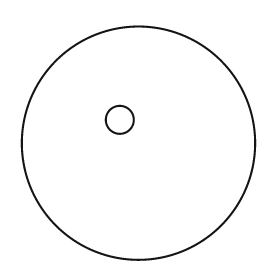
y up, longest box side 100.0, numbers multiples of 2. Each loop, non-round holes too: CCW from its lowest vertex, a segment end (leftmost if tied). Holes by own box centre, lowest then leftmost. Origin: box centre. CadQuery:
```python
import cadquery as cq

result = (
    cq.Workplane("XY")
    .moveTo(0.0, 0.0)
    .circle(50.0)
    .moveTo(-8.0, 10.0)
    .circle(6.0)
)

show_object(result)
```